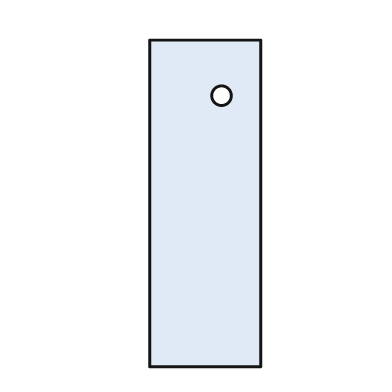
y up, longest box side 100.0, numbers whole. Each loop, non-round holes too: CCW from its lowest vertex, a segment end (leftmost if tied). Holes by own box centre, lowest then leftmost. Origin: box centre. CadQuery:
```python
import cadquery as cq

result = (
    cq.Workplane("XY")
    .moveTo(-17.0, -50.0)
    .lineTo(17.0, -50.0)
    .lineTo(17.0, 50.0)
    .lineTo(-17.0, 50.0)
    .close()
    .moveTo(5.0, 33.0)
    .circle(3.0)
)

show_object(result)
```